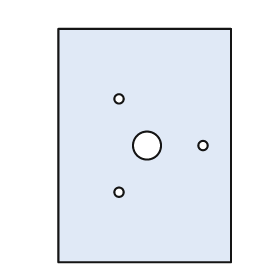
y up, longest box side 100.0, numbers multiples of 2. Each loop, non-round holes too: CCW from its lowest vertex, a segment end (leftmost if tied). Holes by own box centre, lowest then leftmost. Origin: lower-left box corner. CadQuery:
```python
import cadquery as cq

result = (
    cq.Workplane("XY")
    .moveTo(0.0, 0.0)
    .lineTo(74.0, 0.0)
    .lineTo(74.0, 100.0)
    .lineTo(0.0, 100.0)
    .close()
    .moveTo(26.0, 30.0)
    .circle(2.0)
    .moveTo(38.0, 50.0)
    .circle(6.0)
    .moveTo(62.0, 50.0)
    .circle(2.0)
    .moveTo(26.0, 70.0)
    .circle(2.0)
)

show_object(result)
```